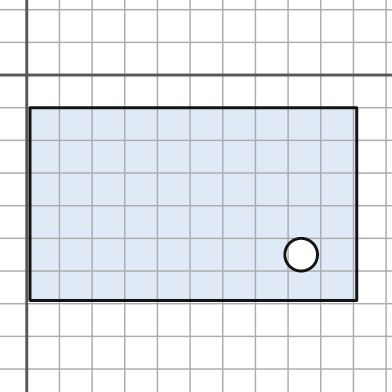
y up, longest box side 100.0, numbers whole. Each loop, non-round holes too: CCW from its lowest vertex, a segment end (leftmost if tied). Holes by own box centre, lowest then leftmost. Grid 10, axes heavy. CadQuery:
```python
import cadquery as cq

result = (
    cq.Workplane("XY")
    .moveTo(1.0, -69.0)
    .lineTo(101.0, -69.0)
    .lineTo(101.0, -10.0)
    .lineTo(1.0, -10.0)
    .close()
    .moveTo(84.0, -55.0)
    .circle(5.0)
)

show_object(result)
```